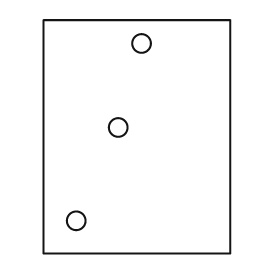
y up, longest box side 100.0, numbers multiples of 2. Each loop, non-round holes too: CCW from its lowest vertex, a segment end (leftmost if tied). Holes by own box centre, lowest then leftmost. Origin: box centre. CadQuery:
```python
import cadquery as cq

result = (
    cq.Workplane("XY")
    .moveTo(-40.0, -50.0)
    .lineTo(40.0, -50.0)
    .lineTo(40.0, 50.0)
    .lineTo(-40.0, 50.0)
    .close()
    .moveTo(-26.0, -36.0)
    .circle(4.0)
    .moveTo(-8.0, 4.0)
    .circle(4.0)
    .moveTo(2.0, 40.0)
    .circle(4.0)
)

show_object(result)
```